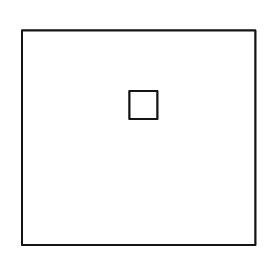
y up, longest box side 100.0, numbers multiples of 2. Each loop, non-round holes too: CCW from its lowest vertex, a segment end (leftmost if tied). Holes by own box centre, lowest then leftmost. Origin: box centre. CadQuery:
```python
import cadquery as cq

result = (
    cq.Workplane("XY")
    .moveTo(-50.0, -46.0)
    .lineTo(50.0, -46.0)
    .lineTo(50.0, 46.0)
    .lineTo(-50.0, 46.0)
    .close()
    .moveTo(-4.0, 8.0)
    .lineTo(8.0, 8.0)
    .lineTo(8.0, 20.0)
    .lineTo(-4.0, 20.0)
    .close()
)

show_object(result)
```